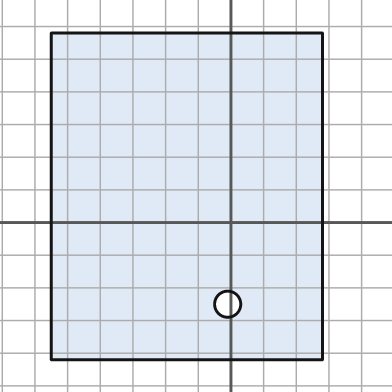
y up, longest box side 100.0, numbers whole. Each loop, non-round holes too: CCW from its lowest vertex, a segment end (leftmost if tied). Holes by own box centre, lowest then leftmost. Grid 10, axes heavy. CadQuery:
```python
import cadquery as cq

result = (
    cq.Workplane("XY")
    .moveTo(-55.0, -42.0)
    .lineTo(28.0, -42.0)
    .lineTo(28.0, 58.0)
    .lineTo(-55.0, 58.0)
    .close()
    .moveTo(-1.0, -25.0)
    .circle(4.0)
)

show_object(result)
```